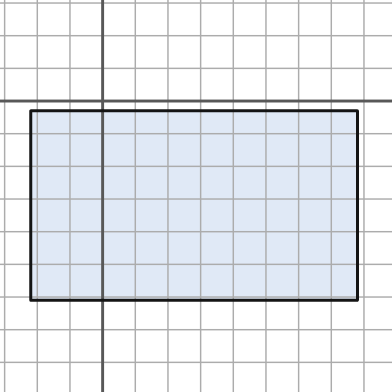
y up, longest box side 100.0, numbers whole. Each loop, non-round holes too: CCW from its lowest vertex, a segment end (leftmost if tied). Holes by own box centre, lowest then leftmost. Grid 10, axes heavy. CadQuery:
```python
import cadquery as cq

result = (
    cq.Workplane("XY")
    .moveTo(-22.0, -61.0)
    .lineTo(78.0, -61.0)
    .lineTo(78.0, -3.0)
    .lineTo(-22.0, -3.0)
    .close()
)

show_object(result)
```